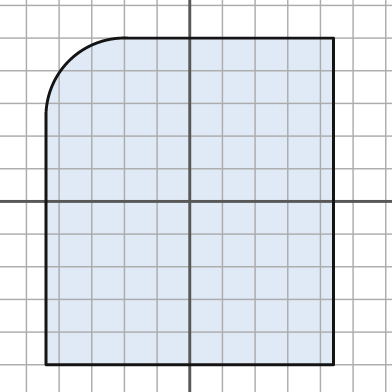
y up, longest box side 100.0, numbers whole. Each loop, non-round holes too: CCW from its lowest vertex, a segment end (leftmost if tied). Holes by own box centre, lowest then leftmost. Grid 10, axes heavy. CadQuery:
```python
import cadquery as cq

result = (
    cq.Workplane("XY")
    .moveTo(-44.0, -50.0)
    .lineTo(44.0, -50.0)
    .lineTo(44.0, 50.0)
    .lineTo(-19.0, 50.0)
    .threePointArc((-37.0, 43.0), (-44.0, 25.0))
    .close()
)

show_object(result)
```